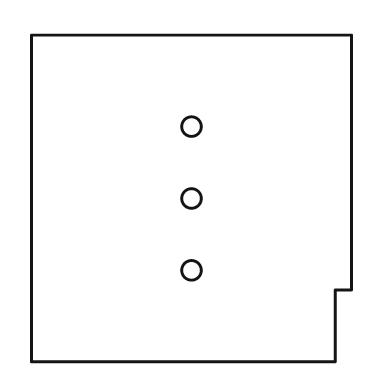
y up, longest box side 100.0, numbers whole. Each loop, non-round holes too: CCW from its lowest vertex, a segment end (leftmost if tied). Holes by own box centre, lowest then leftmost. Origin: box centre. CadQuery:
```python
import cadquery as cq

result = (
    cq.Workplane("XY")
    .moveTo(-49.0, -50.0)
    .lineTo(44.0, -50.0)
    .lineTo(44.0, -28.0)
    .lineTo(49.0, -28.0)
    .lineTo(49.0, 50.0)
    .lineTo(-49.0, 50.0)
    .close()
    .moveTo(0.0, -22.0)
    .circle(3.0)
    .moveTo(0.0, 0.0)
    .circle(3.0)
    .moveTo(0.0, 22.0)
    .circle(3.0)
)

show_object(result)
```